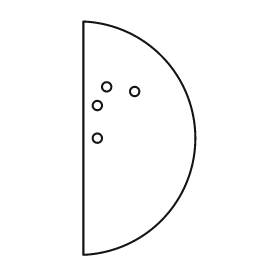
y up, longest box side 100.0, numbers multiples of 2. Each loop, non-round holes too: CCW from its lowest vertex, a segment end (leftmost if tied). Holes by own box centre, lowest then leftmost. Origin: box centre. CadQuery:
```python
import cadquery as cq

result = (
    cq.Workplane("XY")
    .moveTo(-24.0, -50.0)
    .threePointArc((24.0, 0.0), (-24.0, 50.0))
    .close()
    .moveTo(-18.0, 0.0)
    .circle(2.0)
    .moveTo(-18.0, 14.0)
    .circle(2.0)
    .moveTo(-2.0, 20.0)
    .circle(2.0)
    .moveTo(-14.0, 22.0)
    .circle(2.0)
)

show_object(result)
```